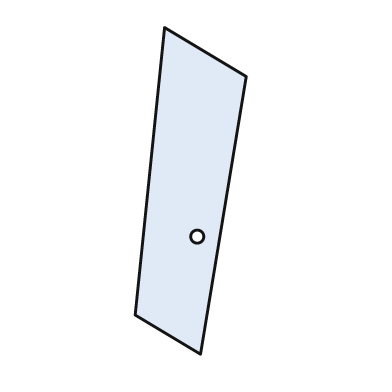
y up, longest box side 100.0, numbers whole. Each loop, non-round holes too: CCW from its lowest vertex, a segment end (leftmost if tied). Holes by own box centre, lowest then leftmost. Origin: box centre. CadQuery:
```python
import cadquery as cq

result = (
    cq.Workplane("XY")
    .moveTo(3.0, -50.0)
    .lineTo(17.0, 35.0)
    .lineTo(-8.0, 50.0)
    .lineTo(-17.0, -38.0)
    .close()
    .moveTo(2.0, -14.0)
    .circle(2.0)
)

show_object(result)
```